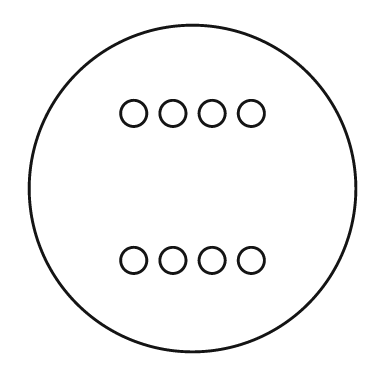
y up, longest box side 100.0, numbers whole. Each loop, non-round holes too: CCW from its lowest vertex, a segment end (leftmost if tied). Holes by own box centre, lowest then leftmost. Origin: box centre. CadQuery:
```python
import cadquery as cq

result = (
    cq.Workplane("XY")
    .moveTo(0.0, 0.0)
    .circle(50.0)
    .moveTo(-18.0, -22.0)
    .circle(4.0)
    .moveTo(-6.0, -22.0)
    .circle(4.0)
    .moveTo(6.0, -22.0)
    .circle(4.0)
    .moveTo(18.0, -22.0)
    .circle(4.0)
    .moveTo(-18.0, 23.0)
    .circle(4.0)
    .moveTo(-6.0, 23.0)
    .circle(4.0)
    .moveTo(6.0, 23.0)
    .circle(4.0)
    .moveTo(18.0, 23.0)
    .circle(4.0)
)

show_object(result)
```